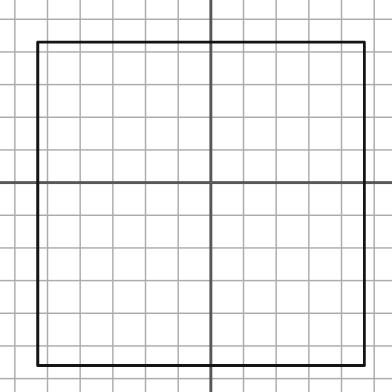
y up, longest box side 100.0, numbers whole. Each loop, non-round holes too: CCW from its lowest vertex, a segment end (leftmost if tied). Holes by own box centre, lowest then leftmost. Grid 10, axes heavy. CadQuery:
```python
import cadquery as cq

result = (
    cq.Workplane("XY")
    .moveTo(-53.0, -56.0)
    .lineTo(47.0, -56.0)
    .lineTo(47.0, 43.0)
    .lineTo(-53.0, 43.0)
    .close()
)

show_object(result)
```